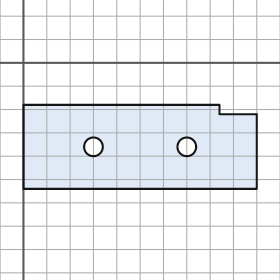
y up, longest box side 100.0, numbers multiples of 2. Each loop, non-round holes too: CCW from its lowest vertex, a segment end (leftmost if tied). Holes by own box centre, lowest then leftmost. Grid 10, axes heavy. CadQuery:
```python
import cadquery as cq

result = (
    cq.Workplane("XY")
    .moveTo(0.0, -54.0)
    .lineTo(100.0, -54.0)
    .lineTo(100.0, -22.0)
    .lineTo(84.0, -22.0)
    .lineTo(84.0, -18.0)
    .lineTo(0.0, -18.0)
    .close()
    .moveTo(30.0, -36.0)
    .circle(4.0)
    .moveTo(70.0, -36.0)
    .circle(4.0)
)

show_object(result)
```